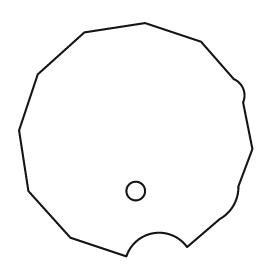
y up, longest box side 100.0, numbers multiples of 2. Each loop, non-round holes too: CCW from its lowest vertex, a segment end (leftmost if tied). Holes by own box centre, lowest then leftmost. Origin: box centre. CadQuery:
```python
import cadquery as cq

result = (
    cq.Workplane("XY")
    .moveTo(-4.0, -50.0)
    .threePointArc((8.0, -40.0), (22.0, -46.0))
    .lineTo(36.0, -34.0)
    .threePointArc((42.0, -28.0), (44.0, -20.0))
    .lineTo(50.0, -4.0)
    .lineTo(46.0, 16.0)
    .threePointArc((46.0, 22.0), (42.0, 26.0))
    .lineTo(28.0, 42.0)
    .lineTo(4.0, 50.0)
    .lineTo(-22.0, 46.0)
    .lineTo(-42.0, 28.0)
    .lineTo(-50.0, 4.0)
    .lineTo(-46.0, -22.0)
    .lineTo(-28.0, -42.0)
    .close()
    .moveTo(0.0, -22.0)
    .circle(4.0)
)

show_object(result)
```